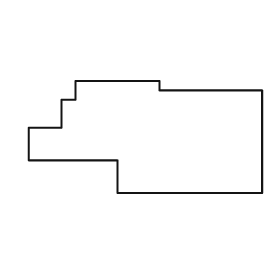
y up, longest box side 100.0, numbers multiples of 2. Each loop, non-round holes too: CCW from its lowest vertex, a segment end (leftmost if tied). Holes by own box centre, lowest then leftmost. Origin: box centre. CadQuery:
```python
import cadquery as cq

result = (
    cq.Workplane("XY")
    .moveTo(-12.0, -24.0)
    .lineTo(50.0, -24.0)
    .lineTo(50.0, 20.0)
    .lineTo(6.0, 20.0)
    .lineTo(6.0, 24.0)
    .lineTo(-30.0, 24.0)
    .lineTo(-30.0, 16.0)
    .lineTo(-36.0, 16.0)
    .lineTo(-36.0, 4.0)
    .lineTo(-50.0, 4.0)
    .lineTo(-50.0, -10.0)
    .lineTo(-12.0, -10.0)
    .close()
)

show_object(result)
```